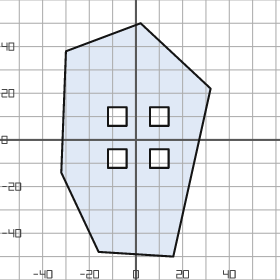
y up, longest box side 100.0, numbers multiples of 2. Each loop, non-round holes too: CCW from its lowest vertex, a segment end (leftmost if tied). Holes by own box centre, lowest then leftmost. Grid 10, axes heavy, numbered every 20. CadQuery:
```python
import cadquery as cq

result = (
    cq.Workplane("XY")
    .moveTo(16.0, -50.0)
    .lineTo(32.0, 22.0)
    .lineTo(2.0, 50.0)
    .lineTo(-30.0, 38.0)
    .lineTo(-32.0, -14.0)
    .lineTo(-16.0, -48.0)
    .close()
    .moveTo(-12.0, -12.0)
    .lineTo(-4.0, -12.0)
    .lineTo(-4.0, -4.0)
    .lineTo(-12.0, -4.0)
    .close()
    .moveTo(6.0, -12.0)
    .lineTo(14.0, -12.0)
    .lineTo(14.0, -4.0)
    .lineTo(6.0, -4.0)
    .close()
    .moveTo(-12.0, 6.0)
    .lineTo(-4.0, 6.0)
    .lineTo(-4.0, 14.0)
    .lineTo(-12.0, 14.0)
    .close()
    .moveTo(6.0, 6.0)
    .lineTo(14.0, 6.0)
    .lineTo(14.0, 14.0)
    .lineTo(6.0, 14.0)
    .close()
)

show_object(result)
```